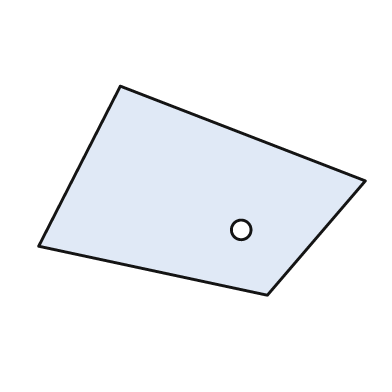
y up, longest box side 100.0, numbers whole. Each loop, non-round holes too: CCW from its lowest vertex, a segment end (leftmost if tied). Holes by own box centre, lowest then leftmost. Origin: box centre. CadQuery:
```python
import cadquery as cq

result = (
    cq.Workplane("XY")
    .moveTo(20.0, -32.0)
    .lineTo(50.0, 3.0)
    .lineTo(-25.0, 32.0)
    .lineTo(-50.0, -17.0)
    .close()
    .moveTo(12.0, -12.0)
    .circle(3.0)
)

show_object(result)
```